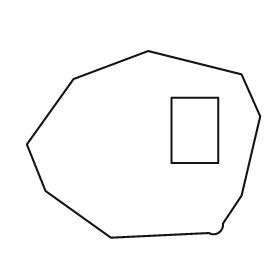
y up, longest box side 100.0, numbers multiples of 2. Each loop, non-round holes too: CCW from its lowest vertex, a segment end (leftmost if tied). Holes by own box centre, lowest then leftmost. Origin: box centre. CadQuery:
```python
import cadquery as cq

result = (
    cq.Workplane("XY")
    .moveTo(-14.0, -40.0)
    .lineTo(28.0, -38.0)
    .threePointArc((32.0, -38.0), (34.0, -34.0))
    .lineTo(42.0, -22.0)
    .lineTo(50.0, 12.0)
    .lineTo(42.0, 30.0)
    .lineTo(2.0, 40.0)
    .lineTo(-30.0, 28.0)
    .lineTo(-50.0, 0.0)
    .lineTo(-42.0, -20.0)
    .close()
    .moveTo(12.0, -8.0)
    .lineTo(32.0, -8.0)
    .lineTo(32.0, 20.0)
    .lineTo(12.0, 20.0)
    .close()
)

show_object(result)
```